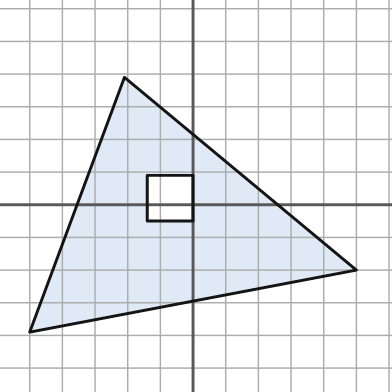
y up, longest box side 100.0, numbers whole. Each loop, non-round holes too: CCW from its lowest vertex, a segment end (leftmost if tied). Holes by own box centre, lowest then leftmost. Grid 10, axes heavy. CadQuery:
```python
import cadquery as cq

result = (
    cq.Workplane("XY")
    .moveTo(-50.0, -39.0)
    .lineTo(50.0, -20.0)
    .lineTo(-21.0, 39.0)
    .close()
    .moveTo(-14.0, -5.0)
    .lineTo(0.0, -5.0)
    .lineTo(0.0, 9.0)
    .lineTo(-14.0, 9.0)
    .close()
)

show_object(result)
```